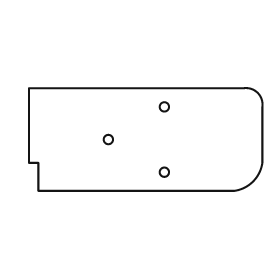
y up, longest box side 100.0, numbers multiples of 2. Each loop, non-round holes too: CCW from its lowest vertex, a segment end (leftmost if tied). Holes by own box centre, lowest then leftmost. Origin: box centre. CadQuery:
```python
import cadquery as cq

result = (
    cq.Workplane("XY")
    .moveTo(-46.0, -22.0)
    .lineTo(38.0, -22.0)
    .threePointArc((46.0, -18.0), (50.0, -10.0))
    .lineTo(50.0, 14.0)
    .threePointArc((48.0, 20.0), (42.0, 22.0))
    .lineTo(-50.0, 22.0)
    .lineTo(-50.0, -10.0)
    .lineTo(-46.0, -10.0)
    .close()
    .moveTo(8.0, -14.0)
    .circle(2.0)
    .moveTo(-16.0, 0.0)
    .circle(2.0)
    .moveTo(8.0, 14.0)
    .circle(2.0)
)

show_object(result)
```